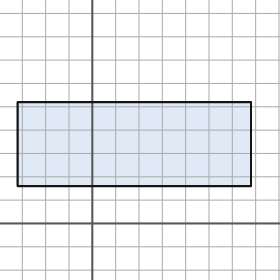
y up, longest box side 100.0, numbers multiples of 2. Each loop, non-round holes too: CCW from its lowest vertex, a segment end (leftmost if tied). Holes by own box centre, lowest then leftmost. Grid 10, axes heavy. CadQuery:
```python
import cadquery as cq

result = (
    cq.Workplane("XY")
    .moveTo(-32.0, 16.0)
    .lineTo(68.0, 16.0)
    .lineTo(68.0, 52.0)
    .lineTo(-32.0, 52.0)
    .close()
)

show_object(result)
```